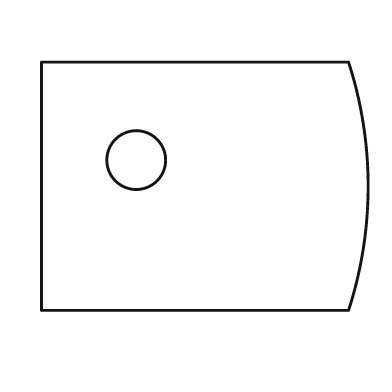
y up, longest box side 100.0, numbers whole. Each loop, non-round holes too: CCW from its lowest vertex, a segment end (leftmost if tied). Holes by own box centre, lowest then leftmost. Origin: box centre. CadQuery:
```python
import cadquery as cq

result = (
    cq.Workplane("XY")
    .moveTo(-50.0, -38.0)
    .lineTo(44.0, -38.0)
    .threePointArc((50.0, 0.0), (44.0, 38.0))
    .lineTo(-50.0, 38.0)
    .close()
    .moveTo(-21.0, 8.0)
    .circle(9.0)
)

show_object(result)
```